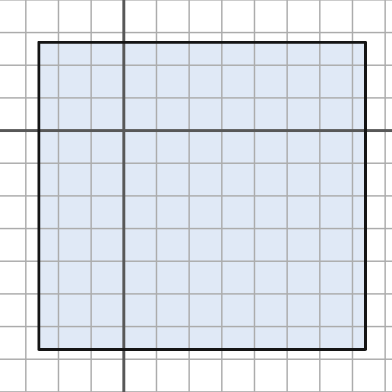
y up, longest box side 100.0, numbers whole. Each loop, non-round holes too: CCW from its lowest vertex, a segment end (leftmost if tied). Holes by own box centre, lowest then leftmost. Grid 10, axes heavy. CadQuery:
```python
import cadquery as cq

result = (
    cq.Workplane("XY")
    .moveTo(-26.0, -67.0)
    .lineTo(74.0, -67.0)
    .lineTo(74.0, 27.0)
    .lineTo(-26.0, 27.0)
    .close()
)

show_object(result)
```